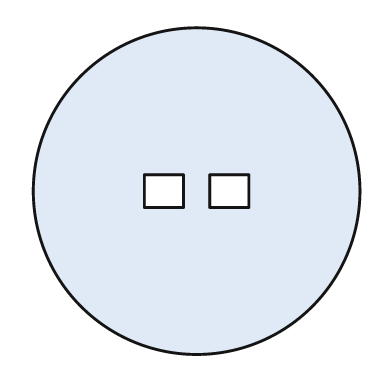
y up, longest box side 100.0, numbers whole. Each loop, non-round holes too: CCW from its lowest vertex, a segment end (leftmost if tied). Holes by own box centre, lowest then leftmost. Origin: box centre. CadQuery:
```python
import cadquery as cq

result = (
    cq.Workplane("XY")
    .moveTo(0.0, 0.0)
    .circle(50.0)
    .moveTo(-16.0, -5.0)
    .lineTo(-4.0, -5.0)
    .lineTo(-4.0, 5.0)
    .lineTo(-16.0, 5.0)
    .close()
    .moveTo(4.0, -5.0)
    .lineTo(16.0, -5.0)
    .lineTo(16.0, 5.0)
    .lineTo(4.0, 5.0)
    .close()
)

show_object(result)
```